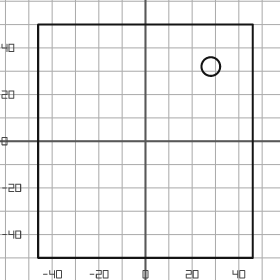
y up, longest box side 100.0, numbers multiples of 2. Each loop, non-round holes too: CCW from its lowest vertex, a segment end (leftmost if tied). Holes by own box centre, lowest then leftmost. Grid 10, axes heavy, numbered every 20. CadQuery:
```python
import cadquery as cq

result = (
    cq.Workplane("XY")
    .moveTo(-46.0, -50.0)
    .lineTo(46.0, -50.0)
    .lineTo(46.0, 50.0)
    .lineTo(-46.0, 50.0)
    .close()
    .moveTo(28.0, 32.0)
    .circle(4.0)
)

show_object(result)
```